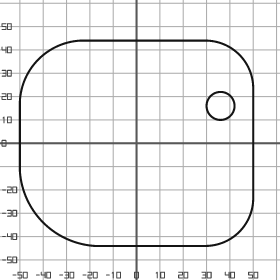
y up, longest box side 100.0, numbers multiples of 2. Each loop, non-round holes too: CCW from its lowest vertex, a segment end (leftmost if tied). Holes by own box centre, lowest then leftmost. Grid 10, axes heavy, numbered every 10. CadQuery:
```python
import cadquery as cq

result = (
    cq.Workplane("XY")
    .moveTo(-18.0, -44.0)
    .lineTo(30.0, -44.0)
    .threePointArc((44.0, -38.0), (50.0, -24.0))
    .lineTo(50.0, 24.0)
    .threePointArc((44.0, 38.0), (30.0, 44.0))
    .lineTo(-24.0, 44.0)
    .threePointArc((-42.0, 36.0), (-50.0, 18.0))
    .lineTo(-50.0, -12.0)
    .threePointArc((-40.0, -34.0), (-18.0, -44.0))
    .close()
    .moveTo(36.0, 16.0)
    .circle(6.0)
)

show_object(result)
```